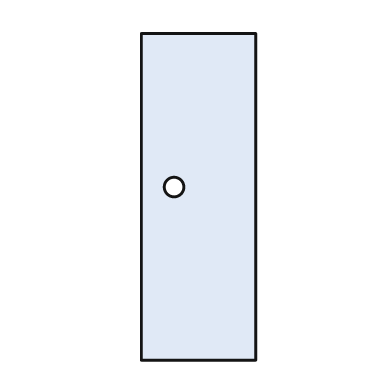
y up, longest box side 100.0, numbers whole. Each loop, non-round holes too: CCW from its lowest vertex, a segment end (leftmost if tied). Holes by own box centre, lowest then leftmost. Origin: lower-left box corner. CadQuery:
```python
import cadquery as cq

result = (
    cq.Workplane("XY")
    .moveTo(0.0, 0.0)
    .lineTo(35.0, 0.0)
    .lineTo(35.0, 100.0)
    .lineTo(0.0, 100.0)
    .close()
    .moveTo(10.0, 53.0)
    .circle(3.0)
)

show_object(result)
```